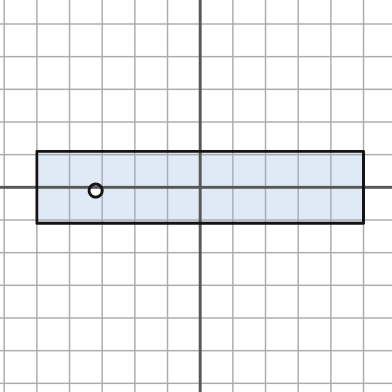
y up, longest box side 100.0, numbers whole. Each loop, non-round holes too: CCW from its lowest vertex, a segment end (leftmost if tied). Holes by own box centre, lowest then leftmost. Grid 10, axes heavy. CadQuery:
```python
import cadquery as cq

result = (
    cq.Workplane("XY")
    .moveTo(-50.0, -11.0)
    .lineTo(50.0, -11.0)
    .lineTo(50.0, 11.0)
    .lineTo(-50.0, 11.0)
    .close()
    .moveTo(-32.0, -1.0)
    .circle(2.0)
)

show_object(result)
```